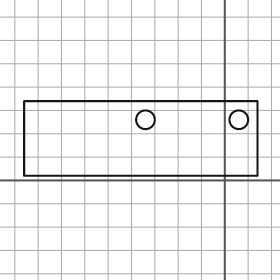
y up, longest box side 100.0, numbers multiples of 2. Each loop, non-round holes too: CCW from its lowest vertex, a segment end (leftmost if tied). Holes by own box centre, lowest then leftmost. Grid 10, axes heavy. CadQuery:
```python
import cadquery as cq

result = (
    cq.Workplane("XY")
    .moveTo(-86.0, 2.0)
    .lineTo(14.0, 2.0)
    .lineTo(14.0, 34.0)
    .lineTo(-86.0, 34.0)
    .close()
    .moveTo(-34.0, 26.0)
    .circle(4.0)
    .moveTo(6.0, 26.0)
    .circle(4.0)
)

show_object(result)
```